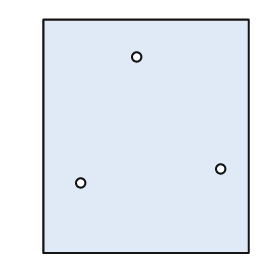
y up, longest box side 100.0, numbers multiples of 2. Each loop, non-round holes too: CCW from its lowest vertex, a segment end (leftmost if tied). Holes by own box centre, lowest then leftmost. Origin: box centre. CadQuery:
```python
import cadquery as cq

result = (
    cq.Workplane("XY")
    .moveTo(-44.0, -50.0)
    .lineTo(44.0, -50.0)
    .lineTo(44.0, 50.0)
    .lineTo(-44.0, 50.0)
    .close()
    .moveTo(-28.0, -20.0)
    .circle(2.0)
    .moveTo(32.0, -14.0)
    .circle(2.0)
    .moveTo(-4.0, 34.0)
    .circle(2.0)
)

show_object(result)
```